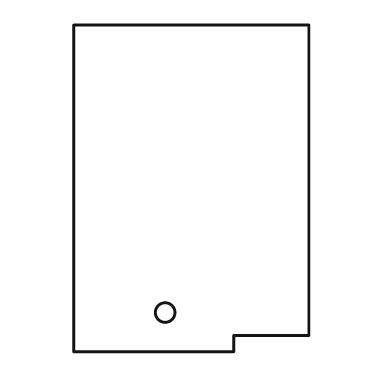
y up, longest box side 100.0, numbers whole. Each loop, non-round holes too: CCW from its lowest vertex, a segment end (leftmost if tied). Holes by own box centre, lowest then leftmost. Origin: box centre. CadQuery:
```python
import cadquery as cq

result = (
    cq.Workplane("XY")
    .moveTo(-36.0, -50.0)
    .lineTo(13.0, -50.0)
    .lineTo(13.0, -45.0)
    .lineTo(36.0, -45.0)
    .lineTo(36.0, 50.0)
    .lineTo(-36.0, 50.0)
    .close()
    .moveTo(-8.0, -38.0)
    .circle(3.0)
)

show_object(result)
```